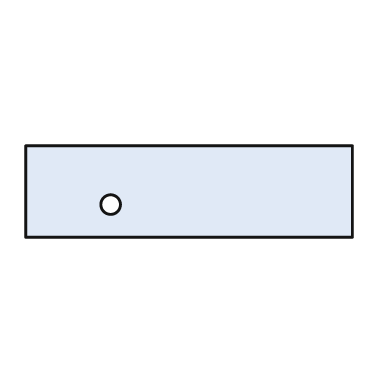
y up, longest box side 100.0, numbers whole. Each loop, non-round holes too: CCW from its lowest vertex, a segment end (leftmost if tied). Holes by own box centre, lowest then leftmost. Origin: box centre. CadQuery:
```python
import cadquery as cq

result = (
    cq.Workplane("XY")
    .moveTo(-50.0, -14.0)
    .lineTo(50.0, -14.0)
    .lineTo(50.0, 14.0)
    .lineTo(-50.0, 14.0)
    .close()
    .moveTo(-24.0, -4.0)
    .circle(3.0)
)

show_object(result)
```